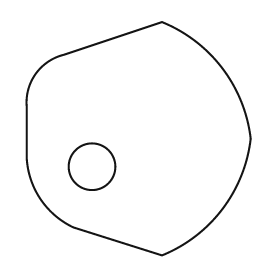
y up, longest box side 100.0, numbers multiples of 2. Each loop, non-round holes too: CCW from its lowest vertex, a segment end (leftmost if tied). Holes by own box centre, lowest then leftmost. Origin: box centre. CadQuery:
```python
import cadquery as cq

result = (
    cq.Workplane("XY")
    .moveTo(10.0, -50.0)
    .threePointArc((36.0, -30.0), (48.0, 0.0))
    .threePointArc((36.0, 30.0), (10.0, 50.0))
    .lineTo(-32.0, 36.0)
    .threePointArc((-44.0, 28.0), (-48.0, 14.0))
    .lineTo(-48.0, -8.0)
    .threePointArc((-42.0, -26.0), (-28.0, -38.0))
    .close()
    .moveTo(-20.0, -12.0)
    .circle(10.0)
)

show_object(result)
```